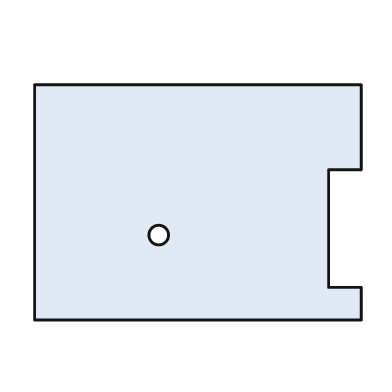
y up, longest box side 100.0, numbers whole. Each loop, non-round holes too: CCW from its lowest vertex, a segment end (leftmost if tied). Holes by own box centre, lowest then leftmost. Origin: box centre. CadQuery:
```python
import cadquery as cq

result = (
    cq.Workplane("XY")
    .moveTo(-50.0, -36.0)
    .lineTo(50.0, -36.0)
    .lineTo(50.0, -26.0)
    .lineTo(40.0, -26.0)
    .lineTo(40.0, 10.0)
    .lineTo(50.0, 10.0)
    .lineTo(50.0, 36.0)
    .lineTo(-50.0, 36.0)
    .close()
    .moveTo(-12.0, -10.0)
    .circle(3.0)
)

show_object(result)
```